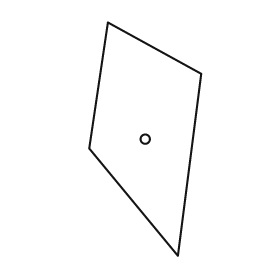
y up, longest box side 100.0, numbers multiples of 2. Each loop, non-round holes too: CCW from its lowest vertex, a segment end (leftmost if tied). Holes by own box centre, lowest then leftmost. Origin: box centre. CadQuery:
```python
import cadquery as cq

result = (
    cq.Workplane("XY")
    .moveTo(14.0, -50.0)
    .lineTo(24.0, 28.0)
    .lineTo(-16.0, 50.0)
    .lineTo(-24.0, -4.0)
    .close()
    .moveTo(0.0, 0.0)
    .circle(2.0)
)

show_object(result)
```